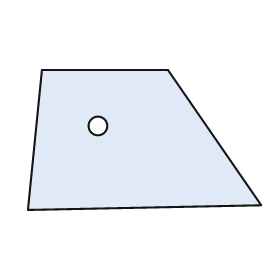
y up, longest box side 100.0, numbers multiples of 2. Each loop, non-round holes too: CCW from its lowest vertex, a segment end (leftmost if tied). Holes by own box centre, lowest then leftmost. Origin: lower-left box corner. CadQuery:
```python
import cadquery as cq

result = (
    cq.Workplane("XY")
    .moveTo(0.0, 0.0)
    .lineTo(100.0, 2.0)
    .lineTo(60.0, 60.0)
    .lineTo(6.0, 60.0)
    .close()
    .moveTo(30.0, 36.0)
    .circle(4.0)
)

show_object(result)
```